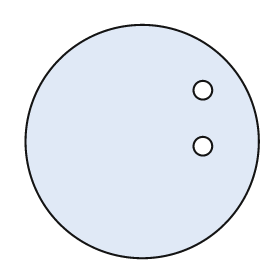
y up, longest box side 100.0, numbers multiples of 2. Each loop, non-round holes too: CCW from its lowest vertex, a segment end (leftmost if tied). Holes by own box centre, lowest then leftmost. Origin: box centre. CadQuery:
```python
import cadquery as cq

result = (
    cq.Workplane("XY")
    .moveTo(0.0, 0.0)
    .circle(50.0)
    .moveTo(26.0, -2.0)
    .circle(4.0)
    .moveTo(26.0, 22.0)
    .circle(4.0)
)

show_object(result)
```